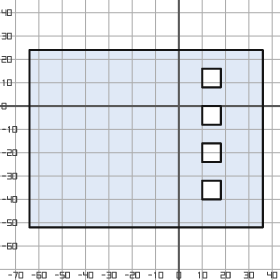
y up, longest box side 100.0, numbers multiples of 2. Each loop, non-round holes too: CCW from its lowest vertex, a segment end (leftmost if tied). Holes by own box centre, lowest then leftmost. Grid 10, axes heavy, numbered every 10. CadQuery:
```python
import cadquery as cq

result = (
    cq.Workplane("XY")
    .moveTo(-64.0, -52.0)
    .lineTo(36.0, -52.0)
    .lineTo(36.0, 24.0)
    .lineTo(-64.0, 24.0)
    .close()
    .moveTo(10.0, -40.0)
    .lineTo(18.0, -40.0)
    .lineTo(18.0, -32.0)
    .lineTo(10.0, -32.0)
    .close()
    .moveTo(10.0, -24.0)
    .lineTo(18.0, -24.0)
    .lineTo(18.0, -16.0)
    .lineTo(10.0, -16.0)
    .close()
    .moveTo(10.0, -8.0)
    .lineTo(18.0, -8.0)
    .lineTo(18.0, 0.0)
    .lineTo(10.0, 0.0)
    .close()
    .moveTo(10.0, 8.0)
    .lineTo(18.0, 8.0)
    .lineTo(18.0, 16.0)
    .lineTo(10.0, 16.0)
    .close()
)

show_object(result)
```